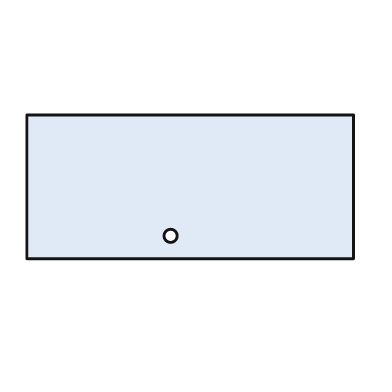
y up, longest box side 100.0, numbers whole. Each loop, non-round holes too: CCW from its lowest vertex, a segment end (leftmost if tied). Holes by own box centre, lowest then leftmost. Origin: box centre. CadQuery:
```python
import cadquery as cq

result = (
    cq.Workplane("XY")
    .moveTo(-50.0, -22.0)
    .lineTo(50.0, -22.0)
    .lineTo(50.0, 22.0)
    .lineTo(-50.0, 22.0)
    .close()
    .moveTo(-6.0, -15.0)
    .circle(2.0)
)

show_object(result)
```